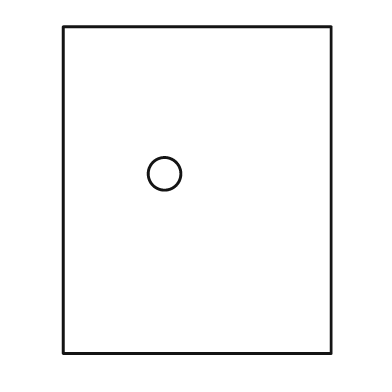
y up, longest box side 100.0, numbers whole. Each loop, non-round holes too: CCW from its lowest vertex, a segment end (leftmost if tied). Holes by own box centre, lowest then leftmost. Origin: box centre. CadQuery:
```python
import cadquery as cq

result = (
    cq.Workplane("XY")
    .moveTo(-41.0, -50.0)
    .lineTo(41.0, -50.0)
    .lineTo(41.0, 50.0)
    .lineTo(-41.0, 50.0)
    .close()
    .moveTo(-10.0, 5.0)
    .circle(5.0)
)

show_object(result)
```